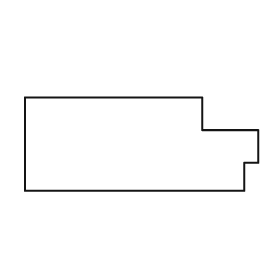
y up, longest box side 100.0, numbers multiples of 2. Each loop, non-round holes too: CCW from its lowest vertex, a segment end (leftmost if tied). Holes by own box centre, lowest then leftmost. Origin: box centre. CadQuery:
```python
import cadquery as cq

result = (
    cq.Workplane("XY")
    .moveTo(-50.0, -20.0)
    .lineTo(44.0, -20.0)
    .lineTo(44.0, -8.0)
    .lineTo(50.0, -8.0)
    .lineTo(50.0, 6.0)
    .lineTo(26.0, 6.0)
    .lineTo(26.0, 20.0)
    .lineTo(-50.0, 20.0)
    .close()
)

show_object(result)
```